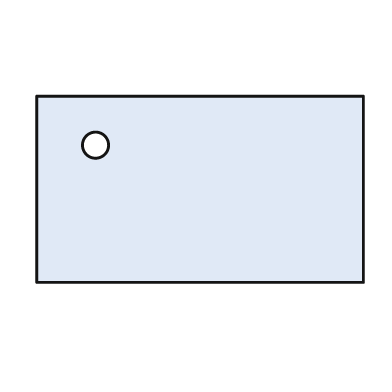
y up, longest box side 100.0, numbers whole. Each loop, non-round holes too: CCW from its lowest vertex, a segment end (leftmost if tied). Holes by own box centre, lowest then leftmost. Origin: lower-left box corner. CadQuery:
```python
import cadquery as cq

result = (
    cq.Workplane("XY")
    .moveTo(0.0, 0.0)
    .lineTo(100.0, 0.0)
    .lineTo(100.0, 57.0)
    .lineTo(0.0, 57.0)
    .close()
    .moveTo(18.0, 42.0)
    .circle(4.0)
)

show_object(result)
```